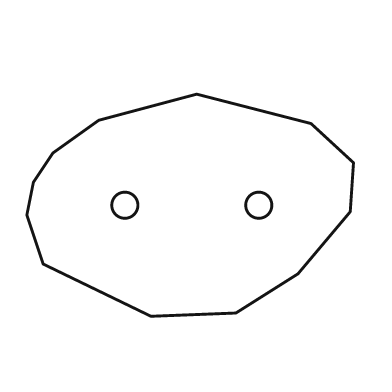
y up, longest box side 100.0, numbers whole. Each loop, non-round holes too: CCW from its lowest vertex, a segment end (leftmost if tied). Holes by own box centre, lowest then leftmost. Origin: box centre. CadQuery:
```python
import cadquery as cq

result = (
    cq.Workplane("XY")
    .moveTo(-12.0, -34.0)
    .lineTo(14.0, -33.0)
    .lineTo(33.0, -21.0)
    .lineTo(49.0, -2.0)
    .lineTo(50.0, 13.0)
    .lineTo(37.0, 25.0)
    .lineTo(2.0, 34.0)
    .lineTo(-28.0, 26.0)
    .lineTo(-42.0, 16.0)
    .lineTo(-48.0, 7.0)
    .lineTo(-50.0, -3.0)
    .lineTo(-45.0, -18.0)
    .close()
    .moveTo(-20.0, 0.0)
    .circle(4.0)
    .moveTo(21.0, 0.0)
    .circle(4.0)
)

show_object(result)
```